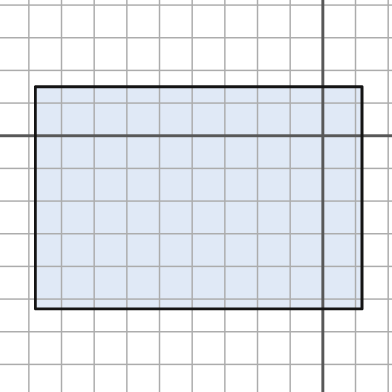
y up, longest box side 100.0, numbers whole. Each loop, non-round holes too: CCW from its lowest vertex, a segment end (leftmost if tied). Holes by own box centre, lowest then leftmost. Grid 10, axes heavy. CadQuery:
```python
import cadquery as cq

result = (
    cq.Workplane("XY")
    .moveTo(-88.0, -53.0)
    .lineTo(12.0, -53.0)
    .lineTo(12.0, 15.0)
    .lineTo(-88.0, 15.0)
    .close()
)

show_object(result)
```